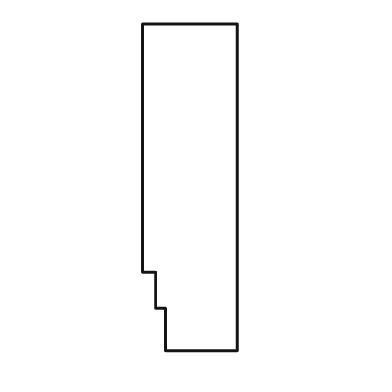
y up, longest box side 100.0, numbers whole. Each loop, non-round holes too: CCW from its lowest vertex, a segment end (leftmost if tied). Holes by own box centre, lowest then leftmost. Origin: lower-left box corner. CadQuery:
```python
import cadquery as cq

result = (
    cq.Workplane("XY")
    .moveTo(7.0, 0.0)
    .lineTo(29.0, 0.0)
    .lineTo(29.0, 100.0)
    .lineTo(0.0, 100.0)
    .lineTo(0.0, 24.0)
    .lineTo(4.0, 24.0)
    .lineTo(4.0, 13.0)
    .lineTo(7.0, 13.0)
    .close()
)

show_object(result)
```